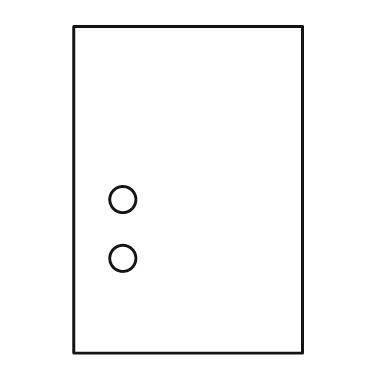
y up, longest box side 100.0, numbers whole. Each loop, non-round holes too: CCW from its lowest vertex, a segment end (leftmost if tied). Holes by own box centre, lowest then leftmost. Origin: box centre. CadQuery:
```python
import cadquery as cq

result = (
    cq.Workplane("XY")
    .moveTo(-35.0, -50.0)
    .lineTo(35.0, -50.0)
    .lineTo(35.0, 50.0)
    .lineTo(-35.0, 50.0)
    .close()
    .moveTo(-20.0, -21.0)
    .circle(4.0)
    .moveTo(-20.0, -3.0)
    .circle(4.0)
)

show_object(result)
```